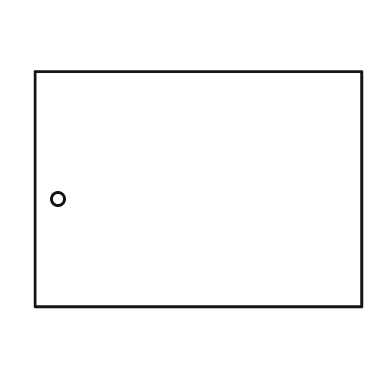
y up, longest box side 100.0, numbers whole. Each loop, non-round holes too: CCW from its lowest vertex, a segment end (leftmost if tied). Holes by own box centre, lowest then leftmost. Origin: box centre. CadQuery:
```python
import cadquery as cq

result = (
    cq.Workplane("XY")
    .moveTo(-50.0, -36.0)
    .lineTo(50.0, -36.0)
    .lineTo(50.0, 36.0)
    .lineTo(-50.0, 36.0)
    .close()
    .moveTo(-43.0, -3.0)
    .circle(2.0)
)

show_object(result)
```